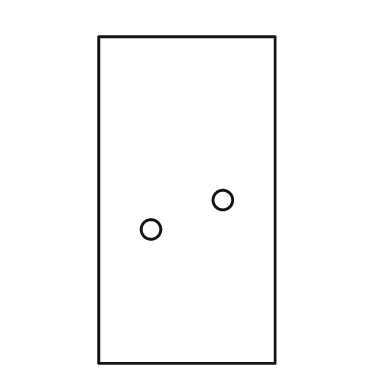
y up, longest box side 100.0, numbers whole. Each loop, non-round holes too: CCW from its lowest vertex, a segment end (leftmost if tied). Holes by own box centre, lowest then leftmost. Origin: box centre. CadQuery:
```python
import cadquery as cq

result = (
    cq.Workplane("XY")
    .moveTo(-27.0, -50.0)
    .lineTo(27.0, -50.0)
    .lineTo(27.0, 50.0)
    .lineTo(-27.0, 50.0)
    .close()
    .moveTo(-11.0, -9.0)
    .circle(3.0)
    .moveTo(11.0, 0.0)
    .circle(3.0)
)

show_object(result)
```